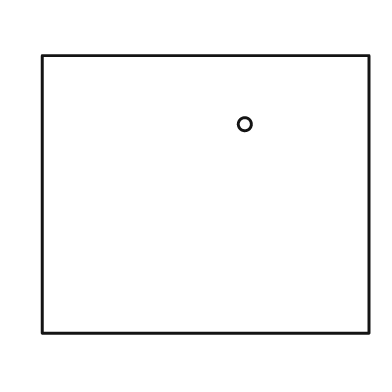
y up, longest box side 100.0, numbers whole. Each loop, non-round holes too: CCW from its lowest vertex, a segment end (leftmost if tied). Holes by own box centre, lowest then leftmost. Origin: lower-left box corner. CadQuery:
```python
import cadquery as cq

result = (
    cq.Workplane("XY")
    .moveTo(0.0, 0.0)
    .lineTo(100.0, 0.0)
    .lineTo(100.0, 85.0)
    .lineTo(0.0, 85.0)
    .close()
    .moveTo(62.0, 64.0)
    .circle(2.0)
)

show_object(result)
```